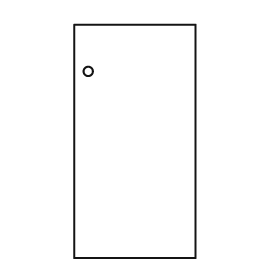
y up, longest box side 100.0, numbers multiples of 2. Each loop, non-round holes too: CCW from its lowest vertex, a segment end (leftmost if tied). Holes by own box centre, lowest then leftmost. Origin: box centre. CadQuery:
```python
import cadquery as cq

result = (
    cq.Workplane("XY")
    .moveTo(-26.0, -50.0)
    .lineTo(26.0, -50.0)
    .lineTo(26.0, 50.0)
    .lineTo(-26.0, 50.0)
    .close()
    .moveTo(-20.0, 30.0)
    .circle(2.0)
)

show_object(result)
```